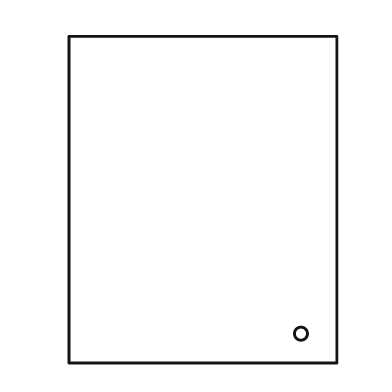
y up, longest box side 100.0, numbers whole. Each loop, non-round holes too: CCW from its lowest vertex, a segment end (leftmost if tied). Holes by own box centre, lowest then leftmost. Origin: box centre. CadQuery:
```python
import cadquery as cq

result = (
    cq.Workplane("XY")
    .moveTo(-41.0, -50.0)
    .lineTo(41.0, -50.0)
    .lineTo(41.0, 50.0)
    .lineTo(-41.0, 50.0)
    .close()
    .moveTo(30.0, -41.0)
    .circle(2.0)
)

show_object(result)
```